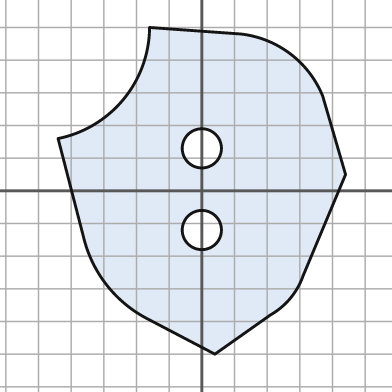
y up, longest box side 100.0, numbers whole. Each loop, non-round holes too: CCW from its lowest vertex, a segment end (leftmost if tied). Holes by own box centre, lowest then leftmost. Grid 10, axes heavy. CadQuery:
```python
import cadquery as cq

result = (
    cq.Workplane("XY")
    .moveTo(4.0, -50.0)
    .lineTo(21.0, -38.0)
    .threePointArc((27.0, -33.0), (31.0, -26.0))
    .lineTo(44.0, 5.0)
    .lineTo(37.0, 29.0)
    .threePointArc((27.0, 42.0), (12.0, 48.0))
    .lineTo(-16.0, 50.0)
    .threePointArc((-24.0, 28.0), (-44.0, 16.0))
    .lineTo(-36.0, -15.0)
    .threePointArc((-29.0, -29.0), (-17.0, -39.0))
    .close()
    .moveTo(0.0, -12.0)
    .circle(6.0)
    .moveTo(0.0, 13.0)
    .circle(6.0)
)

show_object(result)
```